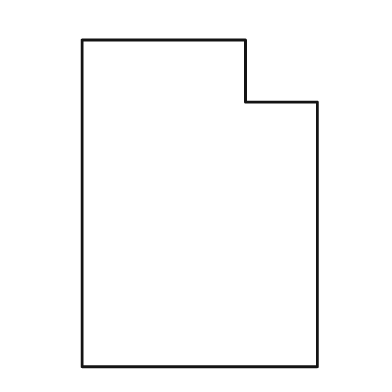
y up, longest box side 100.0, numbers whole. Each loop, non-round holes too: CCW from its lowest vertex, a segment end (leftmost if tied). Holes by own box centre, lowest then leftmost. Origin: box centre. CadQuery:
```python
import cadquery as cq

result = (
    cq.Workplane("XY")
    .moveTo(-36.0, -50.0)
    .lineTo(36.0, -50.0)
    .lineTo(36.0, 31.0)
    .lineTo(14.0, 31.0)
    .lineTo(14.0, 50.0)
    .lineTo(-36.0, 50.0)
    .close()
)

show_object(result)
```